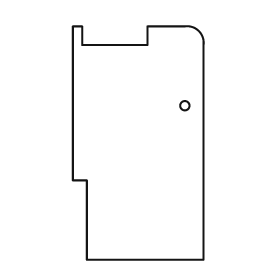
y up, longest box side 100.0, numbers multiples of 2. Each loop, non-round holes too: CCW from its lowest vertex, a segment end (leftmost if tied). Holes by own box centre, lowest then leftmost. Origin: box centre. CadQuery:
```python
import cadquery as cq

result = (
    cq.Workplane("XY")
    .moveTo(-22.0, -50.0)
    .lineTo(28.0, -50.0)
    .lineTo(28.0, 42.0)
    .threePointArc((26.0, 48.0), (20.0, 50.0))
    .lineTo(4.0, 50.0)
    .lineTo(4.0, 42.0)
    .lineTo(-24.0, 42.0)
    .lineTo(-24.0, 50.0)
    .lineTo(-28.0, 50.0)
    .lineTo(-28.0, -16.0)
    .lineTo(-22.0, -16.0)
    .close()
    .moveTo(20.0, 16.0)
    .circle(2.0)
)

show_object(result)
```